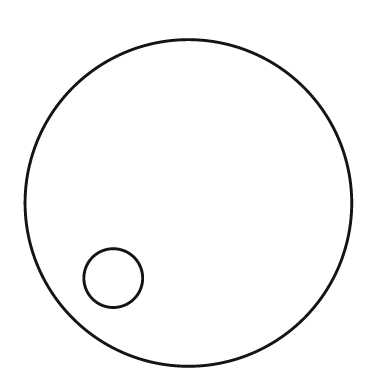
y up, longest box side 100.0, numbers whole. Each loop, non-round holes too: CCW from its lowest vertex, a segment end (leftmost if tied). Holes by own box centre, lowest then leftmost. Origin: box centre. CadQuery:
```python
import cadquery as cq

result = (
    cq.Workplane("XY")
    .moveTo(0.0, 0.0)
    .circle(50.0)
    .moveTo(-23.0, -23.0)
    .circle(9.0)
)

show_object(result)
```